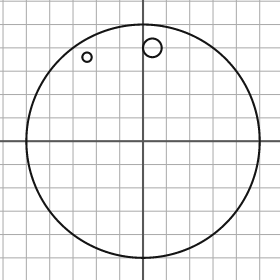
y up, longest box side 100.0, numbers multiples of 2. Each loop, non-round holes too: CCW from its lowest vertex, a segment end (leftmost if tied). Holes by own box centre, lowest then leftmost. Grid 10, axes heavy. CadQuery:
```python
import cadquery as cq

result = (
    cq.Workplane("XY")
    .moveTo(0.0, 0.0)
    .circle(50.0)
    .moveTo(-24.0, 36.0)
    .circle(2.0)
    .moveTo(4.0, 40.0)
    .circle(4.0)
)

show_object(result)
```